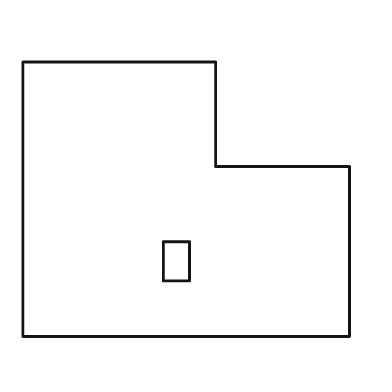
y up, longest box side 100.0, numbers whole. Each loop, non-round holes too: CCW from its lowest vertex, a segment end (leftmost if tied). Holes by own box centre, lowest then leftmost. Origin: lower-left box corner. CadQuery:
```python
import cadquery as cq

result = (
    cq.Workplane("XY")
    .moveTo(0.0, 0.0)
    .lineTo(100.0, 0.0)
    .lineTo(100.0, 52.0)
    .lineTo(59.0, 52.0)
    .lineTo(59.0, 84.0)
    .lineTo(0.0, 84.0)
    .close()
    .moveTo(43.0, 17.0)
    .lineTo(51.0, 17.0)
    .lineTo(51.0, 29.0)
    .lineTo(43.0, 29.0)
    .close()
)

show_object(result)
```